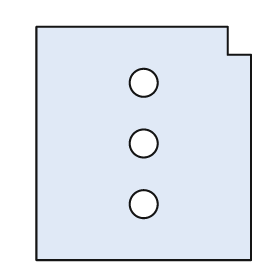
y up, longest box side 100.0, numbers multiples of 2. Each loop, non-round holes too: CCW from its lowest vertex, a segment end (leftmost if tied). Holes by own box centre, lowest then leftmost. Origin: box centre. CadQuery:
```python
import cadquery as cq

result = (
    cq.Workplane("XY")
    .moveTo(-46.0, -50.0)
    .lineTo(46.0, -50.0)
    .lineTo(46.0, 38.0)
    .lineTo(36.0, 38.0)
    .lineTo(36.0, 50.0)
    .lineTo(-46.0, 50.0)
    .close()
    .moveTo(0.0, -26.0)
    .circle(6.0)
    .moveTo(0.0, 0.0)
    .circle(6.0)
    .moveTo(0.0, 26.0)
    .circle(6.0)
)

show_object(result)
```